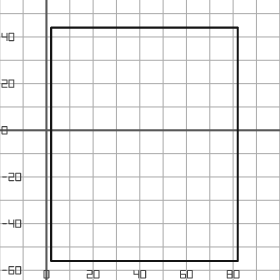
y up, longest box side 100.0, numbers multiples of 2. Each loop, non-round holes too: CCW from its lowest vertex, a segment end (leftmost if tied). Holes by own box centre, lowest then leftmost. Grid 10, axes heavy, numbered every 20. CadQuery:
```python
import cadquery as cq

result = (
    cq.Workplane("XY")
    .moveTo(2.0, -56.0)
    .lineTo(82.0, -56.0)
    .lineTo(82.0, 44.0)
    .lineTo(2.0, 44.0)
    .close()
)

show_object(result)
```